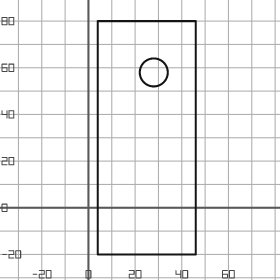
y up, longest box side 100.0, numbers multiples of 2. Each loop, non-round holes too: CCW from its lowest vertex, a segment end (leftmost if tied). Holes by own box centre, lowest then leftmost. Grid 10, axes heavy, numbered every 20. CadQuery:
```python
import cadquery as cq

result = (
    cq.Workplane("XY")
    .moveTo(4.0, -20.0)
    .lineTo(46.0, -20.0)
    .lineTo(46.0, 80.0)
    .lineTo(4.0, 80.0)
    .close()
    .moveTo(28.0, 58.0)
    .circle(6.0)
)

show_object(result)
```